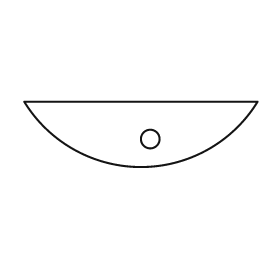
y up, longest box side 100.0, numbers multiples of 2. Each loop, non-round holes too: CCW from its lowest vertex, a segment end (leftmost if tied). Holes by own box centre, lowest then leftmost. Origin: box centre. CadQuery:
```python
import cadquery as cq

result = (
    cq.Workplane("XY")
    .moveTo(-50.0, 14.0)
    .threePointArc((0.0, -14.0), (50.0, 14.0))
    .close()
    .moveTo(4.0, -2.0)
    .circle(4.0)
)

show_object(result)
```